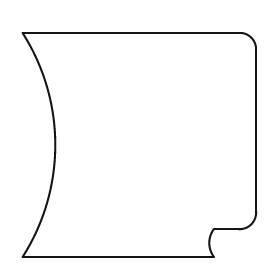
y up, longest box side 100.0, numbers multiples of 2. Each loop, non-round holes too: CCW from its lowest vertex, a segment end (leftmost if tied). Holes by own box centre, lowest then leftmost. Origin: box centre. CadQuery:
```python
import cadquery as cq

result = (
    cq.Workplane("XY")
    .moveTo(-50.0, -48.0)
    .lineTo(32.0, -48.0)
    .threePointArc((30.0, -42.0), (32.0, -36.0))
    .lineTo(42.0, -36.0)
    .threePointArc((48.0, -34.0), (50.0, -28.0))
    .lineTo(50.0, 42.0)
    .threePointArc((48.0, 46.0), (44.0, 48.0))
    .lineTo(-50.0, 48.0)
    .threePointArc((-36.0, 0.0), (-50.0, -48.0))
    .close()
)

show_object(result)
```